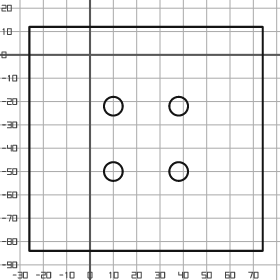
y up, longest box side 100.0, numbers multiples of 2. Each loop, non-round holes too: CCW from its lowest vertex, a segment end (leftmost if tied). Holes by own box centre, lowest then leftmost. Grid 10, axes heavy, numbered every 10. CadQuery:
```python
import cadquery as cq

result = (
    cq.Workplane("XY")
    .moveTo(-26.0, -84.0)
    .lineTo(74.0, -84.0)
    .lineTo(74.0, 12.0)
    .lineTo(-26.0, 12.0)
    .close()
    .moveTo(10.0, -50.0)
    .circle(4.0)
    .moveTo(38.0, -50.0)
    .circle(4.0)
    .moveTo(10.0, -22.0)
    .circle(4.0)
    .moveTo(38.0, -22.0)
    .circle(4.0)
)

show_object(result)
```